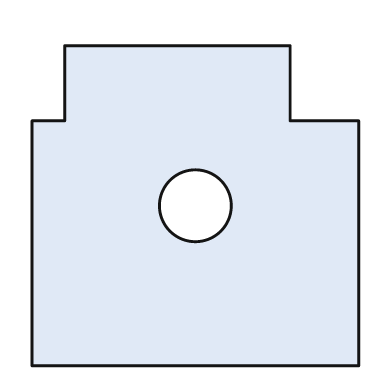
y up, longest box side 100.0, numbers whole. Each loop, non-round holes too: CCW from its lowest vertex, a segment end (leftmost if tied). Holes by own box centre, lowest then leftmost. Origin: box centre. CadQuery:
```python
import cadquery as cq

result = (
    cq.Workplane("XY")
    .moveTo(-50.0, -49.0)
    .lineTo(50.0, -49.0)
    .lineTo(50.0, 26.0)
    .lineTo(29.0, 26.0)
    .lineTo(29.0, 49.0)
    .lineTo(-40.0, 49.0)
    .lineTo(-40.0, 26.0)
    .lineTo(-50.0, 26.0)
    .close()
    .moveTo(0.0, 0.0)
    .circle(11.0)
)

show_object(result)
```